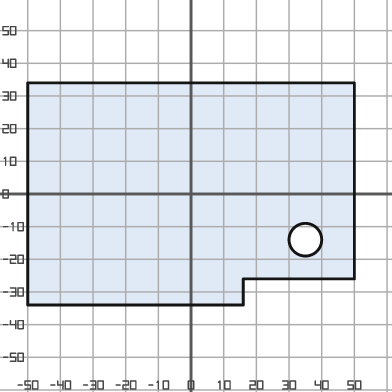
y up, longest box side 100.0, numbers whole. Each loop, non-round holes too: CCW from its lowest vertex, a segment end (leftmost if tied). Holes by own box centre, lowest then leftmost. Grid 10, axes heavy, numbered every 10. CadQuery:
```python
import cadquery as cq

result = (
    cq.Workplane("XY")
    .moveTo(-50.0, -34.0)
    .lineTo(16.0, -34.0)
    .lineTo(16.0, -26.0)
    .lineTo(50.0, -26.0)
    .lineTo(50.0, 34.0)
    .lineTo(-50.0, 34.0)
    .close()
    .moveTo(35.0, -14.0)
    .circle(5.0)
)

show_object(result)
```